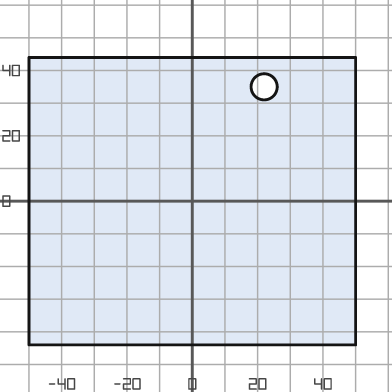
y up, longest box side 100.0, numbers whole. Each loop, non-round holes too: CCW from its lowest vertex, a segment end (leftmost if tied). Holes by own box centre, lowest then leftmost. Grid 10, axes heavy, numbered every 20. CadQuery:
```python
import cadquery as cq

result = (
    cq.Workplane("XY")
    .moveTo(-50.0, -44.0)
    .lineTo(50.0, -44.0)
    .lineTo(50.0, 44.0)
    .lineTo(-50.0, 44.0)
    .close()
    .moveTo(22.0, 35.0)
    .circle(4.0)
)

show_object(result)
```